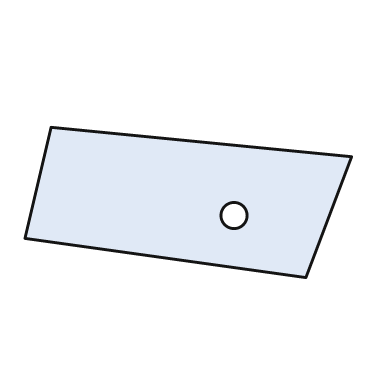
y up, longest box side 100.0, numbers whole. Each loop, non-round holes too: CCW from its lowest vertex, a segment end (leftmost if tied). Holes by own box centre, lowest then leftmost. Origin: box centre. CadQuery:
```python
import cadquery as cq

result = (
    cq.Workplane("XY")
    .moveTo(36.0, -23.0)
    .lineTo(50.0, 14.0)
    .lineTo(-42.0, 23.0)
    .lineTo(-50.0, -11.0)
    .close()
    .moveTo(14.0, -4.0)
    .circle(4.0)
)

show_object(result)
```